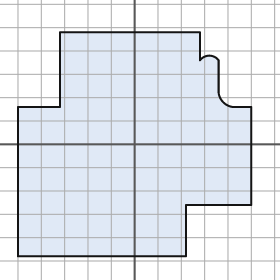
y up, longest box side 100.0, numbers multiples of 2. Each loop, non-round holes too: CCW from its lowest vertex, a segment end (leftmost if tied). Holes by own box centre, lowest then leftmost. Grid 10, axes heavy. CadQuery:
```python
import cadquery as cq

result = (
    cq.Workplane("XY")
    .moveTo(-50.0, -48.0)
    .lineTo(22.0, -48.0)
    .lineTo(22.0, -26.0)
    .lineTo(50.0, -26.0)
    .lineTo(50.0, 16.0)
    .lineTo(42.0, 16.0)
    .threePointArc((38.0, 18.0), (36.0, 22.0))
    .lineTo(36.0, 36.0)
    .threePointArc((32.0, 38.0), (28.0, 36.0))
    .lineTo(28.0, 48.0)
    .lineTo(-32.0, 48.0)
    .lineTo(-32.0, 16.0)
    .lineTo(-50.0, 16.0)
    .close()
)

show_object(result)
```